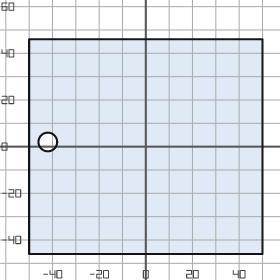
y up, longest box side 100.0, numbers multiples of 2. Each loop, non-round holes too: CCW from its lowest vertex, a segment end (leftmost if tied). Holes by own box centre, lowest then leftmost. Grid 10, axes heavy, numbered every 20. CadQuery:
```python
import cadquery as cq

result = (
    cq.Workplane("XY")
    .moveTo(-50.0, -46.0)
    .lineTo(50.0, -46.0)
    .lineTo(50.0, 46.0)
    .lineTo(-50.0, 46.0)
    .close()
    .moveTo(-42.0, 2.0)
    .circle(4.0)
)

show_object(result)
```